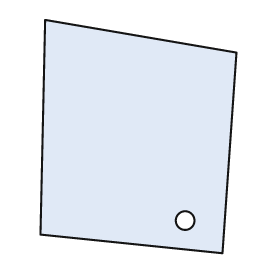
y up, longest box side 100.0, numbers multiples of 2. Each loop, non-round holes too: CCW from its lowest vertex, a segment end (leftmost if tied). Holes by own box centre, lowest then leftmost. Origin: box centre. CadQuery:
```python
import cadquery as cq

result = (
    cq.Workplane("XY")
    .moveTo(36.0, -50.0)
    .lineTo(42.0, 36.0)
    .lineTo(-40.0, 50.0)
    .lineTo(-42.0, -42.0)
    .close()
    .moveTo(20.0, -36.0)
    .circle(4.0)
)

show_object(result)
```